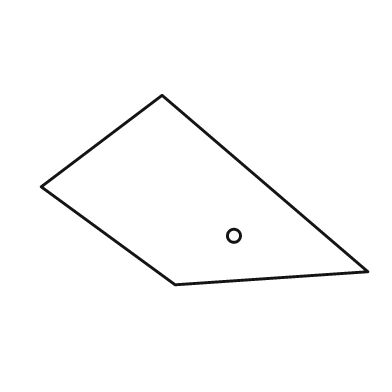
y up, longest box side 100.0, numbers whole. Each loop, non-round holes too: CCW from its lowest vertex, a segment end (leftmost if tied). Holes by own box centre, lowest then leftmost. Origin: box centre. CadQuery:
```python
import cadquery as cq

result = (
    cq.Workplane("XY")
    .moveTo(-9.0, -29.0)
    .lineTo(50.0, -25.0)
    .lineTo(-13.0, 29.0)
    .lineTo(-50.0, 1.0)
    .close()
    .moveTo(9.0, -14.0)
    .circle(2.0)
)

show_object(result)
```